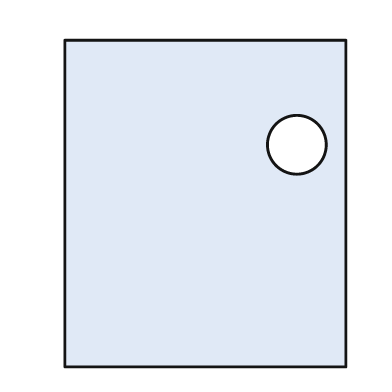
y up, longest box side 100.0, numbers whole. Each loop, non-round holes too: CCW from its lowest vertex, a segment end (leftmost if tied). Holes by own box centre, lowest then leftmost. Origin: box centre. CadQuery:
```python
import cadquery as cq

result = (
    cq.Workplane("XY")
    .moveTo(-43.0, -50.0)
    .lineTo(43.0, -50.0)
    .lineTo(43.0, 50.0)
    .lineTo(-43.0, 50.0)
    .close()
    .moveTo(28.0, 18.0)
    .circle(9.0)
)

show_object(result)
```